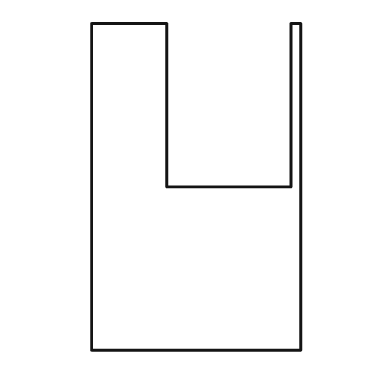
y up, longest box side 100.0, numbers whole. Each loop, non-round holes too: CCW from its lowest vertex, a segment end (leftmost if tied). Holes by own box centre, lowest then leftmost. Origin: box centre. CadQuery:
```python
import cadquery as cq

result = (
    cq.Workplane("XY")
    .moveTo(-32.0, -50.0)
    .lineTo(32.0, -50.0)
    .lineTo(32.0, 50.0)
    .lineTo(29.0, 50.0)
    .lineTo(29.0, 0.0)
    .lineTo(-9.0, 0.0)
    .lineTo(-9.0, 50.0)
    .lineTo(-32.0, 50.0)
    .close()
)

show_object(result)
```